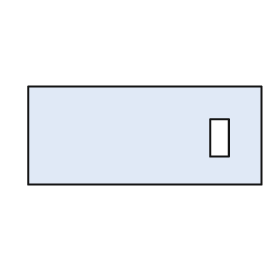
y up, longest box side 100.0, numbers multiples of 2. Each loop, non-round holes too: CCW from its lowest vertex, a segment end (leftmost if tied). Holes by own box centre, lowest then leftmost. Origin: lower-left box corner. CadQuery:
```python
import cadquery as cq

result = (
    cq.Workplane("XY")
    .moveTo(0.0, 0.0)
    .lineTo(100.0, 0.0)
    .lineTo(100.0, 42.0)
    .lineTo(0.0, 42.0)
    .close()
    .moveTo(78.0, 12.0)
    .lineTo(86.0, 12.0)
    .lineTo(86.0, 28.0)
    .lineTo(78.0, 28.0)
    .close()
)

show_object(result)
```